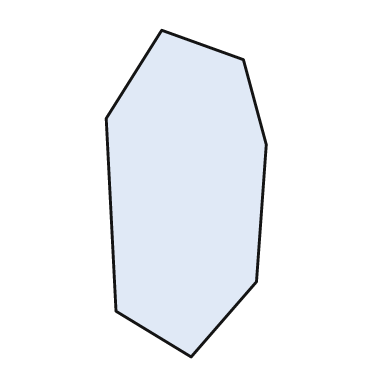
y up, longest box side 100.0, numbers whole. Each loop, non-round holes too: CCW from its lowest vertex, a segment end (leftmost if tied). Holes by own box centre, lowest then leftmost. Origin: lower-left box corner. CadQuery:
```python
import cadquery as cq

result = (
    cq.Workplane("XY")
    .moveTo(26.0, 0.0)
    .lineTo(46.0, 23.0)
    .lineTo(49.0, 65.0)
    .lineTo(42.0, 91.0)
    .lineTo(17.0, 100.0)
    .lineTo(0.0, 73.0)
    .lineTo(3.0, 14.0)
    .close()
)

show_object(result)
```